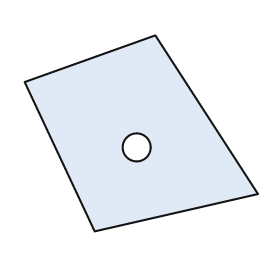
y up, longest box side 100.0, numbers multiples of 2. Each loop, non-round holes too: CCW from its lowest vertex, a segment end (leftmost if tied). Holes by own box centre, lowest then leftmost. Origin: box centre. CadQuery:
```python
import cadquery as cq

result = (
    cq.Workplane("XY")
    .moveTo(-20.0, -42.0)
    .lineTo(50.0, -26.0)
    .lineTo(6.0, 42.0)
    .lineTo(-50.0, 22.0)
    .close()
    .moveTo(-2.0, -6.0)
    .circle(6.0)
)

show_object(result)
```